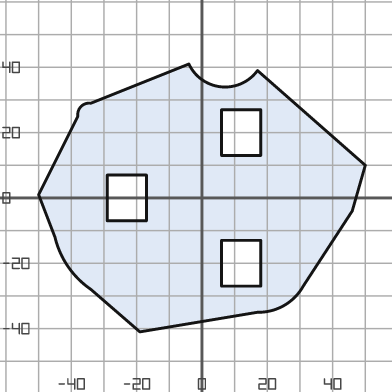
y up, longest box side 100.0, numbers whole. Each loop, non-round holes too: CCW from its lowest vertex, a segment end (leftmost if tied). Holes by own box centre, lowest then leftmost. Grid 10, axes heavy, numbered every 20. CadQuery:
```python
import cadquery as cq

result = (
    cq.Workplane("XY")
    .moveTo(-19.0, -41.0)
    .lineTo(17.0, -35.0)
    .threePointArc((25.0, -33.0), (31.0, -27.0))
    .lineTo(46.0, -4.0)
    .lineTo(50.0, 10.0)
    .lineTo(17.0, 39.0)
    .threePointArc((6.0, 34.0), (-4.0, 41.0))
    .lineTo(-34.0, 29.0)
    .threePointArc((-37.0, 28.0), (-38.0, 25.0))
    .lineTo(-50.0, 1.0)
    .lineTo(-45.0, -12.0)
    .threePointArc((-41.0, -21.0), (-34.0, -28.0))
    .close()
    .moveTo(6.0, -27.0)
    .lineTo(18.0, -27.0)
    .lineTo(18.0, -13.0)
    .lineTo(6.0, -13.0)
    .close()
    .moveTo(-29.0, -7.0)
    .lineTo(-17.0, -7.0)
    .lineTo(-17.0, 7.0)
    .lineTo(-29.0, 7.0)
    .close()
    .moveTo(6.0, 13.0)
    .lineTo(18.0, 13.0)
    .lineTo(18.0, 27.0)
    .lineTo(6.0, 27.0)
    .close()
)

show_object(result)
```